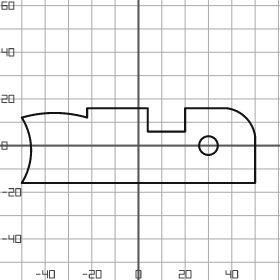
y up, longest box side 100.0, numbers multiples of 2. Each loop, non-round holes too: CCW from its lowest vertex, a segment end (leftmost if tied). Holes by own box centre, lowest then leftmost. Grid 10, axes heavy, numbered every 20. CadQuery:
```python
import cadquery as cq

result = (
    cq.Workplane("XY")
    .moveTo(-50.0, -16.0)
    .lineTo(50.0, -16.0)
    .lineTo(50.0, 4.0)
    .threePointArc((46.0, 12.0), (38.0, 16.0))
    .lineTo(20.0, 16.0)
    .lineTo(20.0, 6.0)
    .lineTo(4.0, 6.0)
    .lineTo(4.0, 16.0)
    .lineTo(-22.0, 16.0)
    .lineTo(-22.0, 12.0)
    .threePointArc((-36.0, 14.0), (-50.0, 12.0))
    .threePointArc((-46.0, -2.0), (-50.0, -16.0))
    .close()
    .moveTo(30.0, 0.0)
    .circle(4.0)
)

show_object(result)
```